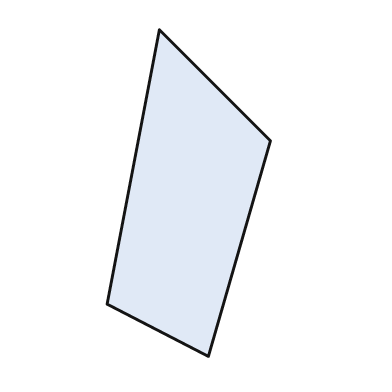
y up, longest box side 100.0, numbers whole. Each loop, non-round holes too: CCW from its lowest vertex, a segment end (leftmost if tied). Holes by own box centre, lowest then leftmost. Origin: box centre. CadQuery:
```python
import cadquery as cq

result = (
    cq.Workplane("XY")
    .moveTo(6.0, -50.0)
    .lineTo(25.0, 16.0)
    .lineTo(-9.0, 50.0)
    .lineTo(-25.0, -34.0)
    .close()
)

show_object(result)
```